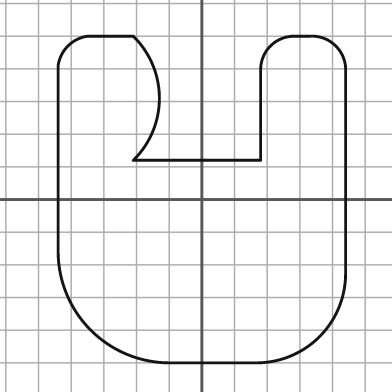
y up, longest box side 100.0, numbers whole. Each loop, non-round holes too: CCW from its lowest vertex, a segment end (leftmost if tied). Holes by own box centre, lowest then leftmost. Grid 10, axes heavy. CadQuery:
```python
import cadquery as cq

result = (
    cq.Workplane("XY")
    .moveTo(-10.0, -50.0)
    .lineTo(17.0, -50.0)
    .threePointArc((36.0, -42.0), (44.0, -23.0))
    .lineTo(44.0, 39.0)
    .threePointArc((41.0, 47.0), (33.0, 50.0))
    .lineTo(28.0, 50.0)
    .threePointArc((21.0, 47.0), (18.0, 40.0))
    .lineTo(18.0, 12.0)
    .lineTo(-21.0, 12.0)
    .threePointArc((-13.0, 31.0), (-21.0, 50.0))
    .lineTo(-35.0, 50.0)
    .threePointArc((-41.0, 47.0), (-44.0, 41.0))
    .lineTo(-44.0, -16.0)
    .threePointArc((-34.0, -40.0), (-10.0, -50.0))
    .close()
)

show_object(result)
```